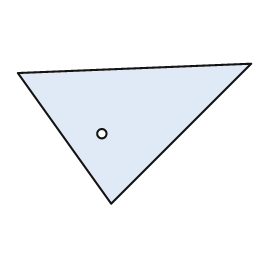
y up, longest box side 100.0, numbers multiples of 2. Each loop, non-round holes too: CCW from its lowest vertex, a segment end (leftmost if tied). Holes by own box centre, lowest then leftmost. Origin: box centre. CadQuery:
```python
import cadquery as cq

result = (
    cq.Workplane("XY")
    .moveTo(-10.0, -30.0)
    .lineTo(50.0, 30.0)
    .lineTo(-50.0, 26.0)
    .close()
    .moveTo(-14.0, 0.0)
    .circle(2.0)
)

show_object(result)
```